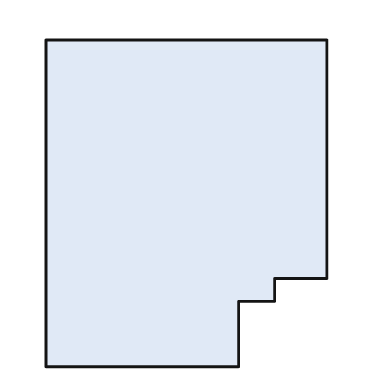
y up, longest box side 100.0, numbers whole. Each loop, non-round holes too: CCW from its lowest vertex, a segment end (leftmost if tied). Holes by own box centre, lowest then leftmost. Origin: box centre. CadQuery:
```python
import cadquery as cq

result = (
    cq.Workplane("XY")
    .moveTo(-43.0, -50.0)
    .lineTo(16.0, -50.0)
    .lineTo(16.0, -30.0)
    .lineTo(27.0, -30.0)
    .lineTo(27.0, -23.0)
    .lineTo(43.0, -23.0)
    .lineTo(43.0, 50.0)
    .lineTo(-43.0, 50.0)
    .close()
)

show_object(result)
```